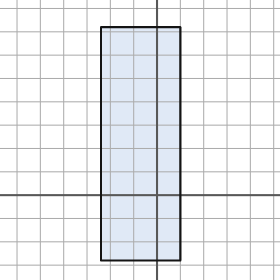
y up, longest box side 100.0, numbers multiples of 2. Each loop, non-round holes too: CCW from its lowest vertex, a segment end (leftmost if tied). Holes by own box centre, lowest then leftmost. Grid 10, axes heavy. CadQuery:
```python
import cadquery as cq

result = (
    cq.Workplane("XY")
    .moveTo(-24.0, -28.0)
    .lineTo(10.0, -28.0)
    .lineTo(10.0, 72.0)
    .lineTo(-24.0, 72.0)
    .close()
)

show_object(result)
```